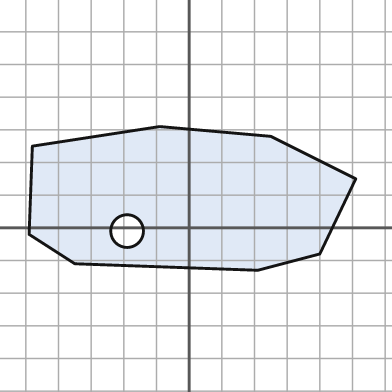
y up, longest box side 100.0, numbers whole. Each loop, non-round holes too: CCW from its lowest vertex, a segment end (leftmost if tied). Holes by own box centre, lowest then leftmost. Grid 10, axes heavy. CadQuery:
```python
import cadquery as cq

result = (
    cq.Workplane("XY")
    .moveTo(21.0, -13.0)
    .lineTo(40.0, -8.0)
    .lineTo(51.0, 15.0)
    .lineTo(25.0, 28.0)
    .lineTo(-9.0, 31.0)
    .lineTo(-48.0, 25.0)
    .lineTo(-49.0, -2.0)
    .lineTo(-35.0, -11.0)
    .close()
    .moveTo(-19.0, -1.0)
    .circle(5.0)
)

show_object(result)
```